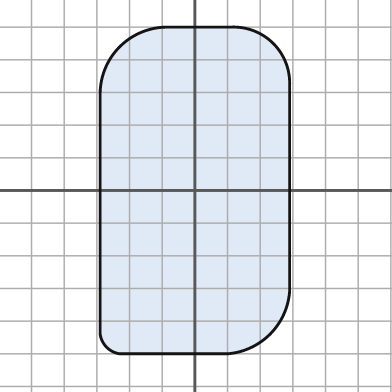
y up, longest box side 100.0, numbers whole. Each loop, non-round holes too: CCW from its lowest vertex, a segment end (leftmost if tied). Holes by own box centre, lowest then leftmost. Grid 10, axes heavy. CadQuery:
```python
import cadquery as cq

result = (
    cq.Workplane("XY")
    .moveTo(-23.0, -50.0)
    .lineTo(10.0, -50.0)
    .threePointArc((23.0, -44.0), (29.0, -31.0))
    .lineTo(29.0, 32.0)
    .threePointArc((24.0, 45.0), (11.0, 50.0))
    .lineTo(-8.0, 50.0)
    .threePointArc((-23.0, 44.0), (-29.0, 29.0))
    .lineTo(-29.0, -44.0)
    .threePointArc((-27.0, -48.0), (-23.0, -50.0))
    .close()
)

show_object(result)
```